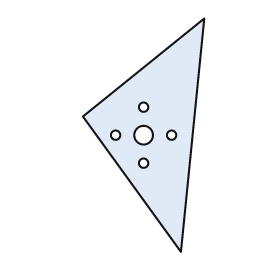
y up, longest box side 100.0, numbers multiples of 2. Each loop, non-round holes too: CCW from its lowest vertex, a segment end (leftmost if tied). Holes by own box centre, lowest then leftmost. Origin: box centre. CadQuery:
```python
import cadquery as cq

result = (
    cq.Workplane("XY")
    .moveTo(16.0, -50.0)
    .lineTo(26.0, 50.0)
    .lineTo(-26.0, 8.0)
    .close()
    .moveTo(0.0, -12.0)
    .circle(2.0)
    .moveTo(-12.0, 0.0)
    .circle(2.0)
    .moveTo(0.0, 0.0)
    .circle(4.0)
    .moveTo(12.0, 0.0)
    .circle(2.0)
    .moveTo(0.0, 12.0)
    .circle(2.0)
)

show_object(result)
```